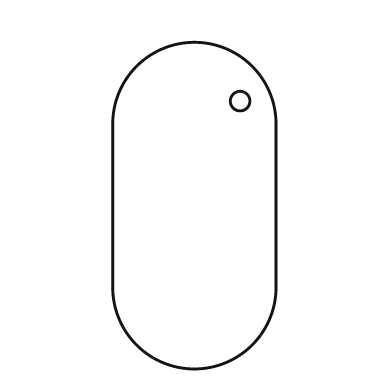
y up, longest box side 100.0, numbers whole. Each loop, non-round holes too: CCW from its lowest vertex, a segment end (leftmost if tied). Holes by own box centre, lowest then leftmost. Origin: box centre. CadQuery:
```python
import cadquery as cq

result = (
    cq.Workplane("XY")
    .moveTo(-25.0, -25.0)
    .threePointArc((0.0, -50.0), (25.0, -25.0))
    .lineTo(25.0, 25.0)
    .threePointArc((0.0, 50.0), (-25.0, 25.0))
    .close()
    .moveTo(14.0, 32.0)
    .circle(3.0)
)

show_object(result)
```